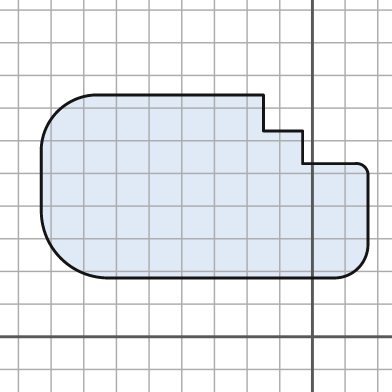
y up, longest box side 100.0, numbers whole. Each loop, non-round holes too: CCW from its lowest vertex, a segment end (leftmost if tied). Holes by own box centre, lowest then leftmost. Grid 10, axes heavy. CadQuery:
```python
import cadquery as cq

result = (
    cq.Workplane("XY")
    .moveTo(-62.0, 18.0)
    .lineTo(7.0, 18.0)
    .threePointArc((14.0, 21.0), (17.0, 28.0))
    .lineTo(17.0, 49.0)
    .threePointArc((16.0, 52.0), (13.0, 53.0))
    .lineTo(-3.0, 53.0)
    .lineTo(-3.0, 63.0)
    .lineTo(-15.0, 63.0)
    .lineTo(-15.0, 74.0)
    .lineTo(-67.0, 74.0)
    .threePointArc((-78.0, 69.0), (-83.0, 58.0))
    .lineTo(-83.0, 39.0)
    .threePointArc((-77.0, 24.0), (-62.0, 18.0))
    .close()
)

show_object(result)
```